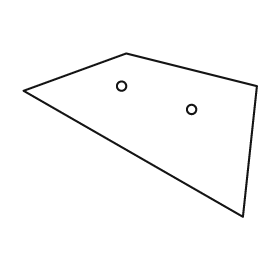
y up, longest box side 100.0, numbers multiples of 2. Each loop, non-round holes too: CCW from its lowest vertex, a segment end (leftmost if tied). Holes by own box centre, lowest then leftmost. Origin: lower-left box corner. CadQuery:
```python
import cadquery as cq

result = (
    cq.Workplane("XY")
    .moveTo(94.0, 0.0)
    .lineTo(100.0, 56.0)
    .lineTo(44.0, 70.0)
    .lineTo(0.0, 54.0)
    .close()
    .moveTo(72.0, 46.0)
    .circle(2.0)
    .moveTo(42.0, 56.0)
    .circle(2.0)
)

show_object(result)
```